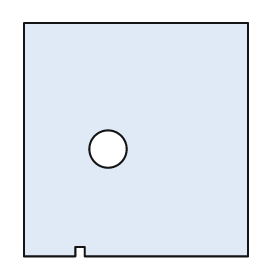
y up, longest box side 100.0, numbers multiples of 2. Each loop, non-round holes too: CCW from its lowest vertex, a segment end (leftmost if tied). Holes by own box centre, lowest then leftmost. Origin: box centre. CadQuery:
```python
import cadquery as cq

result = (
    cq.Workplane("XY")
    .moveTo(-48.0, -50.0)
    .lineTo(-26.0, -50.0)
    .lineTo(-26.0, -46.0)
    .lineTo(-22.0, -46.0)
    .lineTo(-22.0, -50.0)
    .lineTo(48.0, -50.0)
    .lineTo(48.0, 50.0)
    .lineTo(-48.0, 50.0)
    .close()
    .moveTo(-12.0, -4.0)
    .circle(8.0)
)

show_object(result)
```